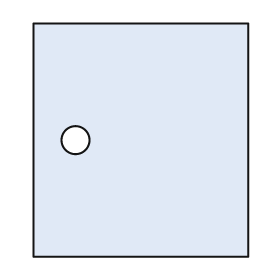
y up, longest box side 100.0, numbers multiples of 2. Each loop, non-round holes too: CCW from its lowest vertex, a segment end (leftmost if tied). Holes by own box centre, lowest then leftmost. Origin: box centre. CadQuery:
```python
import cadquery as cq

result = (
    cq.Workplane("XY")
    .moveTo(-46.0, -50.0)
    .lineTo(46.0, -50.0)
    .lineTo(46.0, 50.0)
    .lineTo(-46.0, 50.0)
    .close()
    .moveTo(-28.0, 0.0)
    .circle(6.0)
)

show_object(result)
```